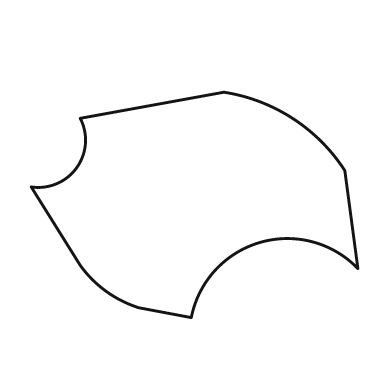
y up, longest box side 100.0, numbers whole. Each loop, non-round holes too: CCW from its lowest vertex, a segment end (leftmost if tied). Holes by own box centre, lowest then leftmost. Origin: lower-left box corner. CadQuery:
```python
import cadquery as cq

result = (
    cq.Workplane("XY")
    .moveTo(49.0, 0.0)
    .threePointArc((70.0, 23.0), (100.0, 15.0))
    .lineTo(96.0, 45.0)
    .threePointArc((80.0, 61.0), (59.0, 69.0))
    .lineTo(15.0, 61.0)
    .threePointArc((14.0, 46.0), (0.0, 40.0))
    .lineTo(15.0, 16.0)
    .threePointArc((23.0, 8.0), (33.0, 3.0))
    .close()
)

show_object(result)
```